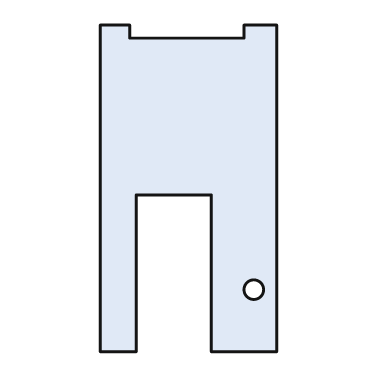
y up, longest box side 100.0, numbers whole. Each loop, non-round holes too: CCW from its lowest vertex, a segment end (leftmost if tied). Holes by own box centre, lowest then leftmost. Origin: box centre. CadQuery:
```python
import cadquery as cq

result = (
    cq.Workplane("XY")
    .moveTo(-27.0, -50.0)
    .lineTo(-16.0, -50.0)
    .lineTo(-16.0, -2.0)
    .lineTo(7.0, -2.0)
    .lineTo(7.0, -50.0)
    .lineTo(27.0, -50.0)
    .lineTo(27.0, 50.0)
    .lineTo(17.0, 50.0)
    .lineTo(17.0, 46.0)
    .lineTo(-18.0, 46.0)
    .lineTo(-18.0, 50.0)
    .lineTo(-27.0, 50.0)
    .close()
    .moveTo(20.0, -31.0)
    .circle(3.0)
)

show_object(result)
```